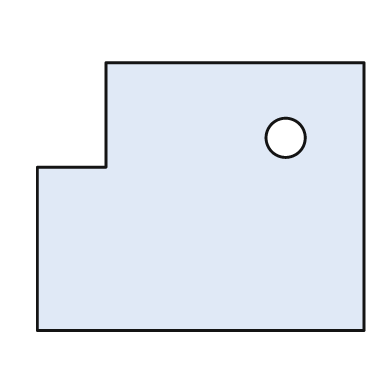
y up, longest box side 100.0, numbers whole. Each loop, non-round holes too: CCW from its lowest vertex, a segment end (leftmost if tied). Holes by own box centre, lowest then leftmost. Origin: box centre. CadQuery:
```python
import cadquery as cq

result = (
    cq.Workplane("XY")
    .moveTo(-50.0, -41.0)
    .lineTo(50.0, -41.0)
    .lineTo(50.0, 41.0)
    .lineTo(-29.0, 41.0)
    .lineTo(-29.0, 9.0)
    .lineTo(-50.0, 9.0)
    .close()
    .moveTo(26.0, 18.0)
    .circle(6.0)
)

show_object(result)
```